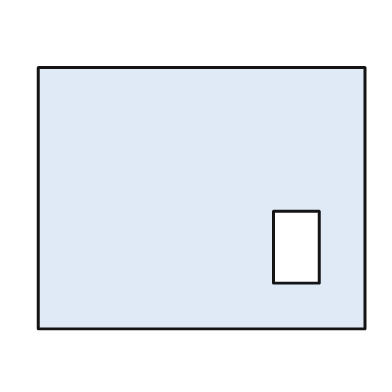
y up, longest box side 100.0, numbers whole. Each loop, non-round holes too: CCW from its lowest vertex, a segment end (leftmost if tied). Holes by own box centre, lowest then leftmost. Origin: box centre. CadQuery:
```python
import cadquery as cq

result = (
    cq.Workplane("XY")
    .moveTo(-50.0, -40.0)
    .lineTo(50.0, -40.0)
    .lineTo(50.0, 40.0)
    .lineTo(-50.0, 40.0)
    .close()
    .moveTo(22.0, -26.0)
    .lineTo(36.0, -26.0)
    .lineTo(36.0, -4.0)
    .lineTo(22.0, -4.0)
    .close()
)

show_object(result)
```